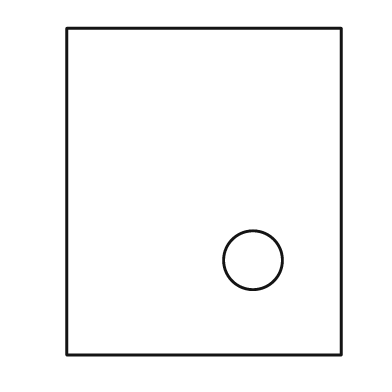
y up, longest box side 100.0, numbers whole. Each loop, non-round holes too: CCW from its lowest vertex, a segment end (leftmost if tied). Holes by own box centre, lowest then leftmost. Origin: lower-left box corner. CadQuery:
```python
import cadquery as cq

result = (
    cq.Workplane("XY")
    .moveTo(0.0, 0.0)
    .lineTo(84.0, 0.0)
    .lineTo(84.0, 100.0)
    .lineTo(0.0, 100.0)
    .close()
    .moveTo(57.0, 29.0)
    .circle(9.0)
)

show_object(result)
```